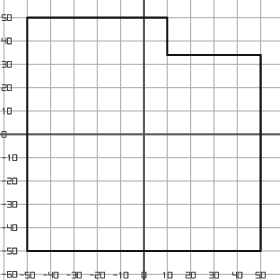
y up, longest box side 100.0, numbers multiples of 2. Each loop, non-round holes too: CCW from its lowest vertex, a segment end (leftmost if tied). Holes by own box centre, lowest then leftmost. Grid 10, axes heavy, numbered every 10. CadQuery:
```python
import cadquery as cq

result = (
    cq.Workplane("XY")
    .moveTo(-50.0, -50.0)
    .lineTo(50.0, -50.0)
    .lineTo(50.0, 34.0)
    .lineTo(10.0, 34.0)
    .lineTo(10.0, 50.0)
    .lineTo(-50.0, 50.0)
    .close()
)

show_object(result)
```